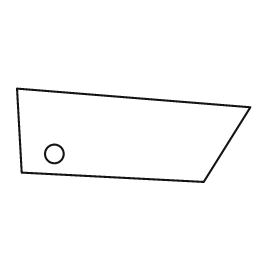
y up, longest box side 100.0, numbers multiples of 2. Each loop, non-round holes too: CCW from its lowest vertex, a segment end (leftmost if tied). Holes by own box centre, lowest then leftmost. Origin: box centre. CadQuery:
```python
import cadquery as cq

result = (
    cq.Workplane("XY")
    .moveTo(30.0, -20.0)
    .lineTo(50.0, 12.0)
    .lineTo(-50.0, 20.0)
    .lineTo(-48.0, -16.0)
    .close()
    .moveTo(-34.0, -8.0)
    .circle(4.0)
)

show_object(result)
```